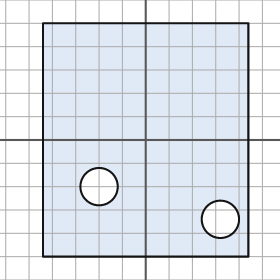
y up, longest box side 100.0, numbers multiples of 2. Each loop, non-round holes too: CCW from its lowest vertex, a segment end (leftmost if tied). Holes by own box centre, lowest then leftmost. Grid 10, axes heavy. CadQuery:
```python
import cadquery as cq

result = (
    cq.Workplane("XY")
    .moveTo(-44.0, -50.0)
    .lineTo(44.0, -50.0)
    .lineTo(44.0, 50.0)
    .lineTo(-44.0, 50.0)
    .close()
    .moveTo(32.0, -34.0)
    .circle(8.0)
    .moveTo(-20.0, -20.0)
    .circle(8.0)
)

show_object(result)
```